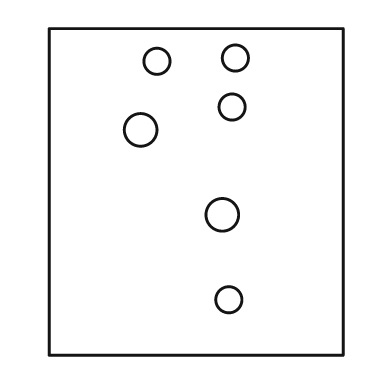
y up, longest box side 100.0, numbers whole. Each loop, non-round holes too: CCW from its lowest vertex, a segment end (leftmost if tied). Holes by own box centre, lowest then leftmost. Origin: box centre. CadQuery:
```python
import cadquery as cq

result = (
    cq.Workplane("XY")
    .moveTo(-45.0, -50.0)
    .lineTo(45.0, -50.0)
    .lineTo(45.0, 50.0)
    .lineTo(-45.0, 50.0)
    .close()
    .moveTo(10.0, -33.0)
    .circle(4.0)
    .moveTo(8.0, -7.0)
    .circle(5.0)
    .moveTo(-17.0, 19.0)
    .circle(5.0)
    .moveTo(11.0, 26.0)
    .circle(4.0)
    .moveTo(-12.0, 40.0)
    .circle(4.0)
    .moveTo(12.0, 41.0)
    .circle(4.0)
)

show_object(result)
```